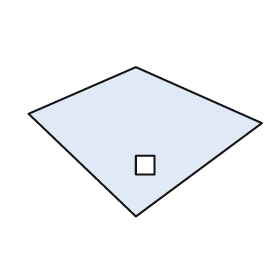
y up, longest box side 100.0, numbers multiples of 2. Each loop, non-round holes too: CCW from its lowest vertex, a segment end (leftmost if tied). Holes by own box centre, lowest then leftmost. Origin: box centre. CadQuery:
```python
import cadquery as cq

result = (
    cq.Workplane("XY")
    .moveTo(-4.0, -32.0)
    .lineTo(50.0, 8.0)
    .lineTo(-4.0, 32.0)
    .lineTo(-50.0, 12.0)
    .close()
    .moveTo(-4.0, -14.0)
    .lineTo(4.0, -14.0)
    .lineTo(4.0, -6.0)
    .lineTo(-4.0, -6.0)
    .close()
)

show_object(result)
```